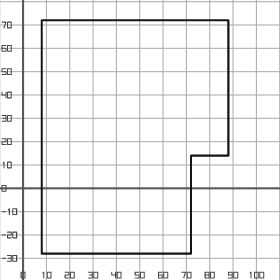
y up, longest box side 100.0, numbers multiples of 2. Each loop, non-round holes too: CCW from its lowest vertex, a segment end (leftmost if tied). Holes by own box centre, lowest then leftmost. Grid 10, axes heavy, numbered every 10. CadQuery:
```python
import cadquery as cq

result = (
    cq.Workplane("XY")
    .moveTo(8.0, -28.0)
    .lineTo(72.0, -28.0)
    .lineTo(72.0, 14.0)
    .lineTo(88.0, 14.0)
    .lineTo(88.0, 72.0)
    .lineTo(8.0, 72.0)
    .close()
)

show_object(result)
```